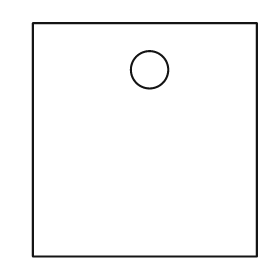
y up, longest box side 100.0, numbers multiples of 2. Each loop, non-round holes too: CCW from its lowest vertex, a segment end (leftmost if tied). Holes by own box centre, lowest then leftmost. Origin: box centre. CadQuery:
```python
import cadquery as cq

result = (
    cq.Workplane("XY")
    .moveTo(-48.0, -50.0)
    .lineTo(48.0, -50.0)
    .lineTo(48.0, 50.0)
    .lineTo(-48.0, 50.0)
    .close()
    .moveTo(2.0, 30.0)
    .circle(8.0)
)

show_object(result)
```